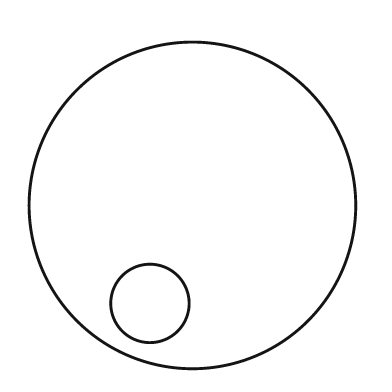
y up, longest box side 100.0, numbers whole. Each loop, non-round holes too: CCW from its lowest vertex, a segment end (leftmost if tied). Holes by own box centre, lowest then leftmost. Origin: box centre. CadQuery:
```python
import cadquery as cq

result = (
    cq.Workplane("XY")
    .moveTo(0.0, 0.0)
    .circle(50.0)
    .moveTo(-13.0, -30.0)
    .circle(12.0)
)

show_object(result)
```